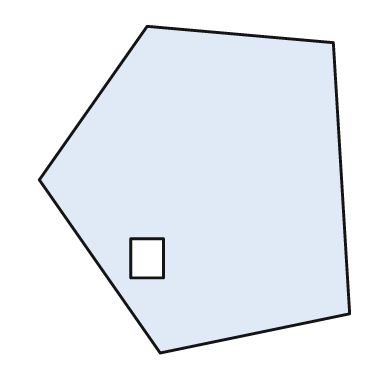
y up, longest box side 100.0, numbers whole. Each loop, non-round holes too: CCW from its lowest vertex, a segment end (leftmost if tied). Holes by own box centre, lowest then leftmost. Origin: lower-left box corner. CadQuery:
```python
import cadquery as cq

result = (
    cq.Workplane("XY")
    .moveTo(37.0, 0.0)
    .lineTo(95.0, 12.0)
    .lineTo(90.0, 95.0)
    .lineTo(33.0, 100.0)
    .lineTo(0.0, 53.0)
    .close()
    .moveTo(28.0, 23.0)
    .lineTo(38.0, 23.0)
    .lineTo(38.0, 35.0)
    .lineTo(28.0, 35.0)
    .close()
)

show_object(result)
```